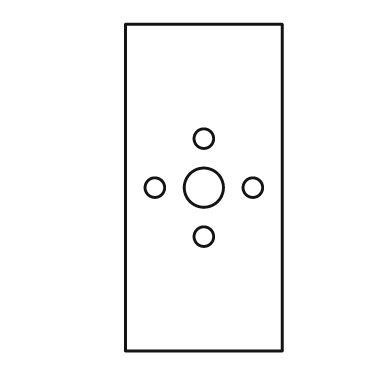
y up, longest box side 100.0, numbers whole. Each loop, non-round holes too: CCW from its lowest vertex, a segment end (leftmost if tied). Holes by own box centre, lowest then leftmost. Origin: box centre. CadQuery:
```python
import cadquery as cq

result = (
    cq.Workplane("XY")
    .moveTo(-24.0, -50.0)
    .lineTo(24.0, -50.0)
    .lineTo(24.0, 50.0)
    .lineTo(-24.0, 50.0)
    .close()
    .moveTo(0.0, -15.0)
    .circle(3.0)
    .moveTo(-15.0, 0.0)
    .circle(3.0)
    .moveTo(0.0, 0.0)
    .circle(6.0)
    .moveTo(15.0, 0.0)
    .circle(3.0)
    .moveTo(0.0, 15.0)
    .circle(3.0)
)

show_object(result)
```